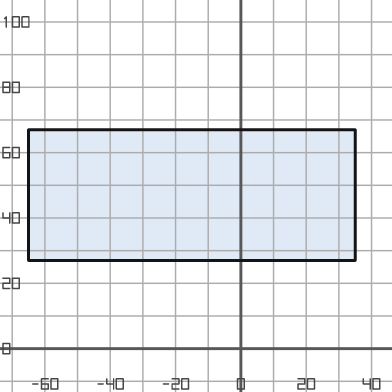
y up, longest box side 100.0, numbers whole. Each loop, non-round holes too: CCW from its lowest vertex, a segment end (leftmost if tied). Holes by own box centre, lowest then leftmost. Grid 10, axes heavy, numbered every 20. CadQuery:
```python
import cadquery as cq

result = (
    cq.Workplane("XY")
    .moveTo(-65.0, 27.0)
    .lineTo(35.0, 27.0)
    .lineTo(35.0, 67.0)
    .lineTo(-65.0, 67.0)
    .close()
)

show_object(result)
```